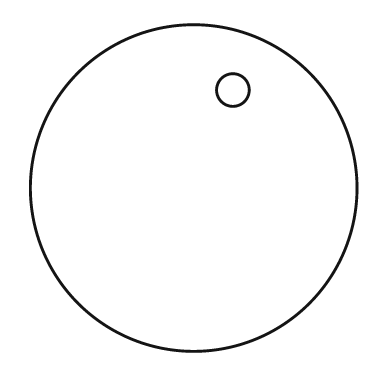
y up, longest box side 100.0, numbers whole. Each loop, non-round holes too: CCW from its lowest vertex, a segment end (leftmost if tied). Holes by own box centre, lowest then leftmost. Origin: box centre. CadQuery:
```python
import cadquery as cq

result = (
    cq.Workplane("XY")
    .moveTo(0.0, 0.0)
    .circle(50.0)
    .moveTo(12.0, 30.0)
    .circle(5.0)
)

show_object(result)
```